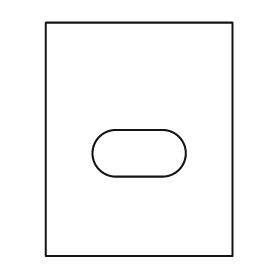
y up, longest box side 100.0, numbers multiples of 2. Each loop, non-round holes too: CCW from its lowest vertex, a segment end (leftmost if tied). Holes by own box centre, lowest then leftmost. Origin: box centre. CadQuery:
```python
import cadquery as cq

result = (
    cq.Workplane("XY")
    .moveTo(-40.0, -50.0)
    .lineTo(40.0, -50.0)
    .lineTo(40.0, 50.0)
    .lineTo(-40.0, 50.0)
    .close()
    .moveTo(-10.0, -16.0)
    .lineTo(10.0, -16.0)
    .threePointArc((20.0, -6.0), (10.0, 4.0))
    .lineTo(-10.0, 4.0)
    .threePointArc((-20.0, -6.0), (-10.0, -16.0))
    .close()
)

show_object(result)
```